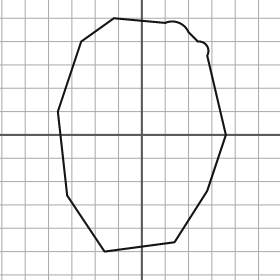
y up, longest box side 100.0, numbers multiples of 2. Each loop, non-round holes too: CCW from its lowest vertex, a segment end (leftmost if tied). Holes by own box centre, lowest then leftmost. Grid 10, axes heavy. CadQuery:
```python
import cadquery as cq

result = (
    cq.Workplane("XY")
    .moveTo(-16.0, -50.0)
    .lineTo(14.0, -46.0)
    .lineTo(28.0, -24.0)
    .lineTo(36.0, 0.0)
    .lineTo(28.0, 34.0)
    .threePointArc((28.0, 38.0), (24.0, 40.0))
    .lineTo(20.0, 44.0)
    .threePointArc((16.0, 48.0), (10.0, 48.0))
    .lineTo(-12.0, 50.0)
    .lineTo(-26.0, 40.0)
    .lineTo(-36.0, 10.0)
    .lineTo(-32.0, -26.0)
    .close()
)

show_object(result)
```